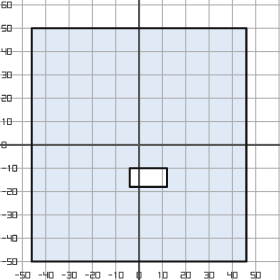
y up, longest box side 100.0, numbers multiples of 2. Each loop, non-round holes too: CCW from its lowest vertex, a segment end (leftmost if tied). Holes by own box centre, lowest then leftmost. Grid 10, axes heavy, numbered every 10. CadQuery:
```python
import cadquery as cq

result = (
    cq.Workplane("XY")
    .moveTo(-46.0, -50.0)
    .lineTo(46.0, -50.0)
    .lineTo(46.0, 50.0)
    .lineTo(-46.0, 50.0)
    .close()
    .moveTo(-4.0, -18.0)
    .lineTo(12.0, -18.0)
    .lineTo(12.0, -10.0)
    .lineTo(-4.0, -10.0)
    .close()
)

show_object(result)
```